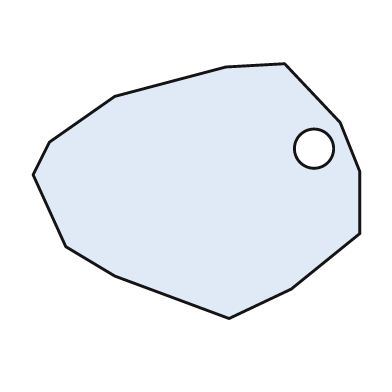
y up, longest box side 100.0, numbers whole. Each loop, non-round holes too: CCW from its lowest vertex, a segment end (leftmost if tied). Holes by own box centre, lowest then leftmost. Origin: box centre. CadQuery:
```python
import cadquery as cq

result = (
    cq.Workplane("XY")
    .moveTo(10.0, -39.0)
    .lineTo(29.0, -30.0)
    .lineTo(50.0, -13.0)
    .lineTo(50.0, 6.0)
    .lineTo(44.0, 21.0)
    .lineTo(27.0, 39.0)
    .lineTo(9.0, 38.0)
    .lineTo(-25.0, 29.0)
    .lineTo(-45.0, 15.0)
    .lineTo(-50.0, 5.0)
    .lineTo(-40.0, -17.0)
    .lineTo(-25.0, -26.0)
    .close()
    .moveTo(36.0, 13.0)
    .circle(6.0)
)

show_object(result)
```